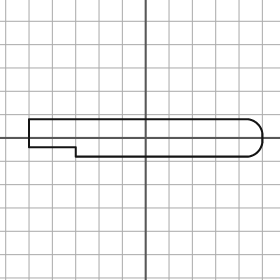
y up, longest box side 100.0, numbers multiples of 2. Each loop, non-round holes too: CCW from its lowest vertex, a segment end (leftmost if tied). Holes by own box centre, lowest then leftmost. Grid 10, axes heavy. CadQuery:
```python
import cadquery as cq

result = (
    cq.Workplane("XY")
    .moveTo(-30.0, -8.0)
    .lineTo(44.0, -8.0)
    .threePointArc((48.0, -6.0), (50.0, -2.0))
    .lineTo(50.0, 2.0)
    .threePointArc((48.0, 6.0), (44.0, 8.0))
    .lineTo(-50.0, 8.0)
    .lineTo(-50.0, -4.0)
    .lineTo(-30.0, -4.0)
    .close()
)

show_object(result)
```